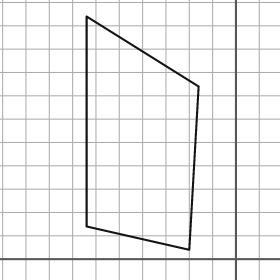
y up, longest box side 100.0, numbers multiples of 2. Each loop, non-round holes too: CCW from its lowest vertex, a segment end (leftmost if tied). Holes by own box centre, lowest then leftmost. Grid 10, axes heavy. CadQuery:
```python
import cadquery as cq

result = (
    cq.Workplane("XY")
    .moveTo(-20.0, 4.0)
    .lineTo(-16.0, 74.0)
    .lineTo(-64.0, 104.0)
    .lineTo(-64.0, 14.0)
    .close()
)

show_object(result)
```